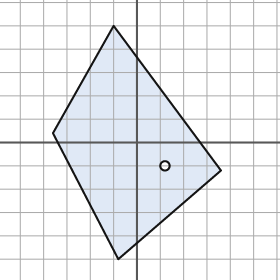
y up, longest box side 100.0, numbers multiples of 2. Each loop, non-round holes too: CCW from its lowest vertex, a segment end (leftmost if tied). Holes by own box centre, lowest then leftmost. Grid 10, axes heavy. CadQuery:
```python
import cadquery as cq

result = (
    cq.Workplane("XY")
    .moveTo(-8.0, -50.0)
    .lineTo(36.0, -12.0)
    .lineTo(-10.0, 50.0)
    .lineTo(-36.0, 4.0)
    .close()
    .moveTo(12.0, -10.0)
    .circle(2.0)
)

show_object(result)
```